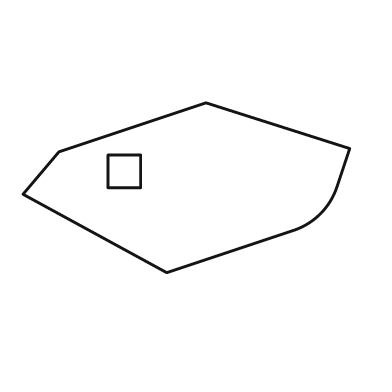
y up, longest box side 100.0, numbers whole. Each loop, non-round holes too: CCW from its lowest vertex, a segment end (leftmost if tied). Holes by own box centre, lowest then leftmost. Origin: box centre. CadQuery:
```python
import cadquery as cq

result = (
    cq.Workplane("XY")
    .moveTo(-6.0, -26.0)
    .lineTo(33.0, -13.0)
    .threePointArc((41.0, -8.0), (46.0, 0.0))
    .lineTo(50.0, 12.0)
    .lineTo(6.0, 26.0)
    .lineTo(-39.0, 11.0)
    .lineTo(-50.0, -2.0)
    .close()
    .moveTo(-24.0, 0.0)
    .lineTo(-14.0, 0.0)
    .lineTo(-14.0, 10.0)
    .lineTo(-24.0, 10.0)
    .close()
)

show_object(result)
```